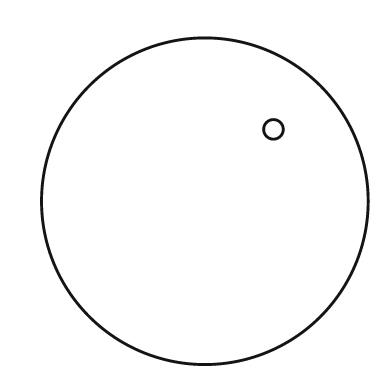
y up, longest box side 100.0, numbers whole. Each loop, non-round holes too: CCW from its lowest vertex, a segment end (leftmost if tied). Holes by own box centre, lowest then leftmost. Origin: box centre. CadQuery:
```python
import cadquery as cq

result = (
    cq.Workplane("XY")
    .moveTo(0.0, 0.0)
    .circle(50.0)
    .moveTo(21.0, 22.0)
    .circle(3.0)
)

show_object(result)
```